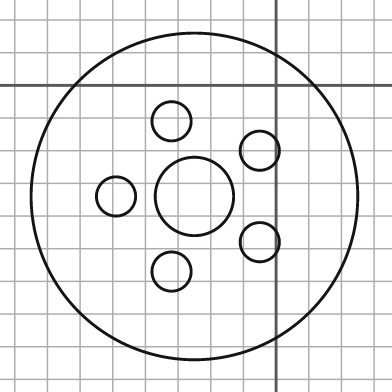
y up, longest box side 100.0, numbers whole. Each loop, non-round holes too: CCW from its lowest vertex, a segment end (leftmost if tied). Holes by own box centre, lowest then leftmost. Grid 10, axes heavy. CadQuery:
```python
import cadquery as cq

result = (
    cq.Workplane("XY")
    .moveTo(-25.0, -34.0)
    .circle(50.0)
    .moveTo(-32.0, -57.0)
    .circle(6.0)
    .moveTo(-5.0, -48.0)
    .circle(6.0)
    .moveTo(-49.0, -34.0)
    .circle(6.0)
    .moveTo(-25.0, -34.0)
    .circle(12.0)
    .moveTo(-5.0, -20.0)
    .circle(6.0)
    .moveTo(-32.0, -11.0)
    .circle(6.0)
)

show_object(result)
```